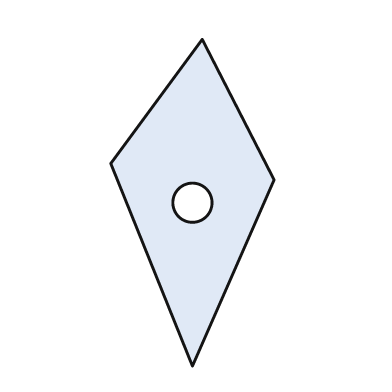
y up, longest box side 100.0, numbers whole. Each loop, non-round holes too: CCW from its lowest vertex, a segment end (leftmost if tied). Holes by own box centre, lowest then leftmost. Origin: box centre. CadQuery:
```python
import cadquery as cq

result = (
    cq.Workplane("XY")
    .moveTo(0.0, -50.0)
    .lineTo(25.0, 7.0)
    .lineTo(3.0, 50.0)
    .lineTo(-25.0, 12.0)
    .close()
    .moveTo(0.0, 0.0)
    .circle(6.0)
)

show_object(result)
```